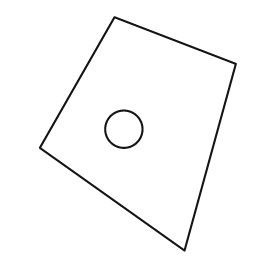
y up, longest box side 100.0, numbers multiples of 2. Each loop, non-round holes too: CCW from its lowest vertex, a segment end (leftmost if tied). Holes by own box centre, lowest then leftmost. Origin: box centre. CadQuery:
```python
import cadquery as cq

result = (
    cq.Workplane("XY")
    .moveTo(20.0, -50.0)
    .lineTo(42.0, 30.0)
    .lineTo(-10.0, 50.0)
    .lineTo(-42.0, -6.0)
    .close()
    .moveTo(-6.0, 2.0)
    .circle(8.0)
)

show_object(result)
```